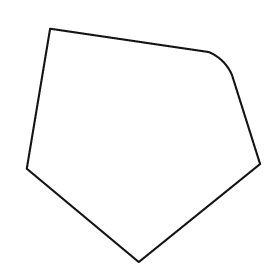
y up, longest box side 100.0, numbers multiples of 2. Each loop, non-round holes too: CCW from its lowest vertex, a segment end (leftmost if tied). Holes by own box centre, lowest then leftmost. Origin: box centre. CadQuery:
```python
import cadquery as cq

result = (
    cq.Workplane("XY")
    .moveTo(-2.0, -50.0)
    .lineTo(50.0, -8.0)
    .lineTo(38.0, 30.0)
    .threePointArc((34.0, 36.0), (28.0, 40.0))
    .lineTo(-40.0, 50.0)
    .lineTo(-50.0, -10.0)
    .close()
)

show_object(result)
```